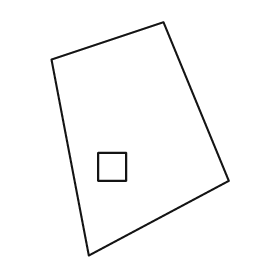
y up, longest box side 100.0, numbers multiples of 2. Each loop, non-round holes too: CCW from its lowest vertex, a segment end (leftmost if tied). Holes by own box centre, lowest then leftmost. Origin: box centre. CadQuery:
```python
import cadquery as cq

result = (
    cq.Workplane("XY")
    .moveTo(-22.0, -50.0)
    .lineTo(38.0, -18.0)
    .lineTo(10.0, 50.0)
    .lineTo(-38.0, 34.0)
    .close()
    .moveTo(-18.0, -18.0)
    .lineTo(-6.0, -18.0)
    .lineTo(-6.0, -6.0)
    .lineTo(-18.0, -6.0)
    .close()
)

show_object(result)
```